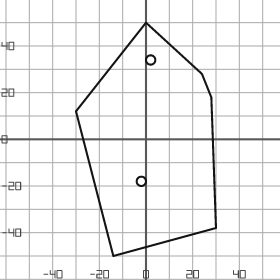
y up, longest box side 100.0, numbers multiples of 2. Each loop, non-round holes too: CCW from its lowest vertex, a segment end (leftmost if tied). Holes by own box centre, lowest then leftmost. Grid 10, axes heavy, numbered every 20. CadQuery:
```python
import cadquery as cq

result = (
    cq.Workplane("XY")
    .moveTo(-14.0, -50.0)
    .lineTo(30.0, -38.0)
    .lineTo(28.0, 18.0)
    .lineTo(24.0, 28.0)
    .lineTo(0.0, 50.0)
    .lineTo(-30.0, 12.0)
    .close()
    .moveTo(-2.0, -18.0)
    .circle(2.0)
    .moveTo(2.0, 34.0)
    .circle(2.0)
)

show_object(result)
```